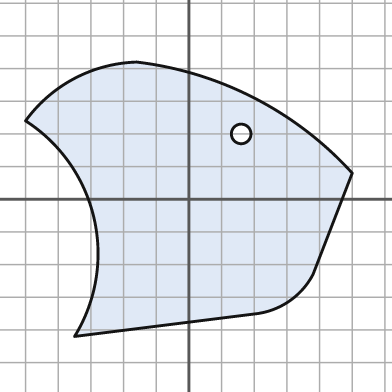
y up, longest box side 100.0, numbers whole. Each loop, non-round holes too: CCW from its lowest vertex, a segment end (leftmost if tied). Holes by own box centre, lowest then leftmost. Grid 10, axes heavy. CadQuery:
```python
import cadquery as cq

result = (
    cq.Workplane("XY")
    .moveTo(-35.0, -42.0)
    .lineTo(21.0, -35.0)
    .threePointArc((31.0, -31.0), (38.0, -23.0))
    .lineTo(50.0, 8.0)
    .threePointArc((20.0, 31.0), (-16.0, 42.0))
    .threePointArc((-35.0, 37.0), (-50.0, 24.0))
    .threePointArc((-29.0, -6.0), (-35.0, -42.0))
    .close()
    .moveTo(16.0, 20.0)
    .circle(3.0)
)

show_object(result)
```